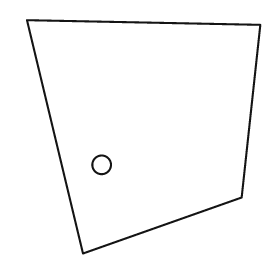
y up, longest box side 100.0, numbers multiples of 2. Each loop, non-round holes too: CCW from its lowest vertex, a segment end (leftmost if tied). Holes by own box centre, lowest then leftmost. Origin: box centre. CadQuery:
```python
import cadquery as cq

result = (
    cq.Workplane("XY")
    .moveTo(-26.0, -50.0)
    .lineTo(42.0, -26.0)
    .lineTo(50.0, 48.0)
    .lineTo(-50.0, 50.0)
    .close()
    .moveTo(-18.0, -12.0)
    .circle(4.0)
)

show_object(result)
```